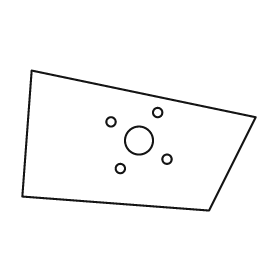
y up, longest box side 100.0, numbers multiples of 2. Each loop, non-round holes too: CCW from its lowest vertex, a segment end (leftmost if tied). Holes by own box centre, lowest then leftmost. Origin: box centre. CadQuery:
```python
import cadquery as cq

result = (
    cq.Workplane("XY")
    .moveTo(30.0, -30.0)
    .lineTo(50.0, 10.0)
    .lineTo(-46.0, 30.0)
    .lineTo(-50.0, -24.0)
    .close()
    .moveTo(-8.0, -12.0)
    .circle(2.0)
    .moveTo(12.0, -8.0)
    .circle(2.0)
    .moveTo(0.0, 0.0)
    .circle(6.0)
    .moveTo(-12.0, 8.0)
    .circle(2.0)
    .moveTo(8.0, 12.0)
    .circle(2.0)
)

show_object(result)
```